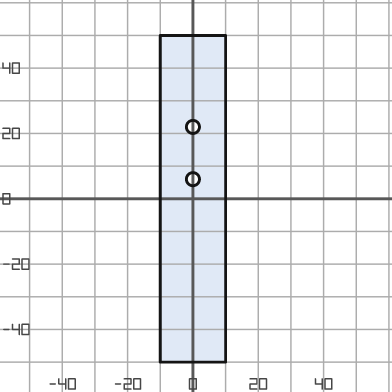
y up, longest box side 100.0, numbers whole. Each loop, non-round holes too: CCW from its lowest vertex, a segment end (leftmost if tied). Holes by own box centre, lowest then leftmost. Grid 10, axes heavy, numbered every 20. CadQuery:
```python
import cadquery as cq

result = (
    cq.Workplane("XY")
    .moveTo(-10.0, -50.0)
    .lineTo(10.0, -50.0)
    .lineTo(10.0, 50.0)
    .lineTo(-10.0, 50.0)
    .close()
    .moveTo(0.0, 6.0)
    .circle(2.0)
    .moveTo(0.0, 22.0)
    .circle(2.0)
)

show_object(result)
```